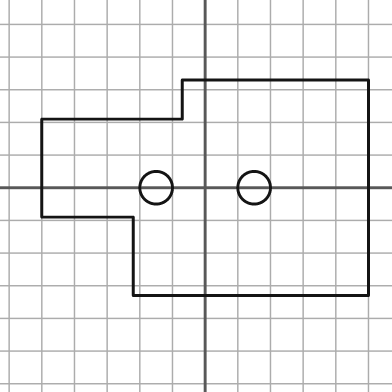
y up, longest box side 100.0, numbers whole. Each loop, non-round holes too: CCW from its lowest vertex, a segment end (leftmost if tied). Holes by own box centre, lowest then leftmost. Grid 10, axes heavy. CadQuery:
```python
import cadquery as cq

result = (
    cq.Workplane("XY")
    .moveTo(-22.0, -33.0)
    .lineTo(50.0, -33.0)
    .lineTo(50.0, 33.0)
    .lineTo(-7.0, 33.0)
    .lineTo(-7.0, 21.0)
    .lineTo(-50.0, 21.0)
    .lineTo(-50.0, -9.0)
    .lineTo(-22.0, -9.0)
    .close()
    .moveTo(-15.0, 0.0)
    .circle(5.0)
    .moveTo(15.0, 0.0)
    .circle(5.0)
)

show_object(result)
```